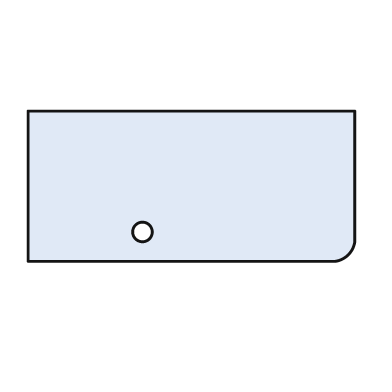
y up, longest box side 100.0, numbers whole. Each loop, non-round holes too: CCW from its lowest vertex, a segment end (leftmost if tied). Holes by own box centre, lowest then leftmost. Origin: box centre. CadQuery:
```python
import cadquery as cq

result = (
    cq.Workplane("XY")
    .moveTo(-50.0, -23.0)
    .lineTo(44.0, -23.0)
    .threePointArc((48.0, -21.0), (50.0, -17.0))
    .lineTo(50.0, 23.0)
    .lineTo(-50.0, 23.0)
    .close()
    .moveTo(-15.0, -14.0)
    .circle(3.0)
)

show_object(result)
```